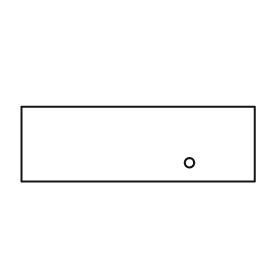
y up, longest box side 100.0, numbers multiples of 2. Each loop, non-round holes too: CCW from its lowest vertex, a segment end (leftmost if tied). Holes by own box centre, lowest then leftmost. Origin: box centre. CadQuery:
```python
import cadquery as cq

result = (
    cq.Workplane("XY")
    .moveTo(-50.0, -16.0)
    .lineTo(50.0, -16.0)
    .lineTo(50.0, 16.0)
    .lineTo(-50.0, 16.0)
    .close()
    .moveTo(22.0, -8.0)
    .circle(2.0)
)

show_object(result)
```